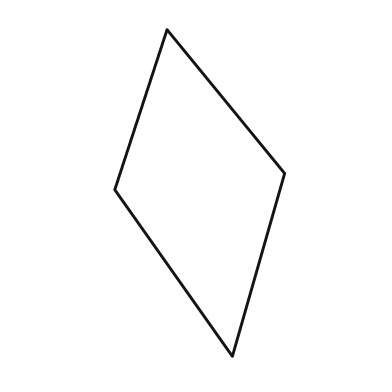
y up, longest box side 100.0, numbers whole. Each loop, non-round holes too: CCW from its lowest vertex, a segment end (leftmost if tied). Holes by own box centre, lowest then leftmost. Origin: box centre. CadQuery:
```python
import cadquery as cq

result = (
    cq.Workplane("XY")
    .moveTo(10.0, -50.0)
    .lineTo(26.0, 6.0)
    .lineTo(-10.0, 50.0)
    .lineTo(-26.0, 1.0)
    .close()
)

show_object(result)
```